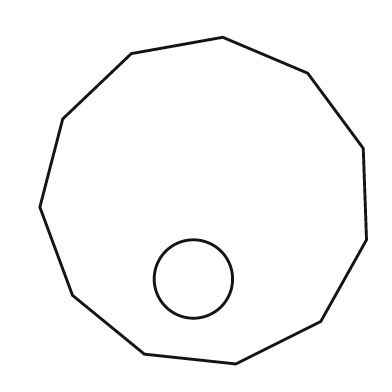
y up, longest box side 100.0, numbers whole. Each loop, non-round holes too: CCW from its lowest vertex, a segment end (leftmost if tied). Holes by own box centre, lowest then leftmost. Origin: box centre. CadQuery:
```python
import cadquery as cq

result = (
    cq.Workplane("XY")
    .moveTo(10.0, -50.0)
    .lineTo(36.0, -37.0)
    .lineTo(50.0, -12.0)
    .lineTo(49.0, 16.0)
    .lineTo(32.0, 39.0)
    .lineTo(6.0, 50.0)
    .lineTo(-22.0, 45.0)
    .lineTo(-43.0, 25.0)
    .lineTo(-50.0, -2.0)
    .lineTo(-40.0, -29.0)
    .lineTo(-18.0, -47.0)
    .close()
    .moveTo(-3.0, -24.0)
    .circle(12.0)
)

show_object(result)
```